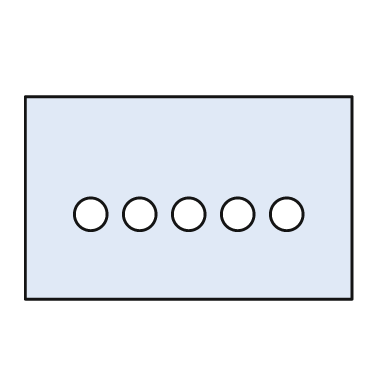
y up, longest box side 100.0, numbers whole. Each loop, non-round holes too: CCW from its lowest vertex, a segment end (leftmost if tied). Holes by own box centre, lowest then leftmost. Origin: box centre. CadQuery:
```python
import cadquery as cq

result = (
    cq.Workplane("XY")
    .moveTo(-50.0, -31.0)
    .lineTo(50.0, -31.0)
    .lineTo(50.0, 31.0)
    .lineTo(-50.0, 31.0)
    .close()
    .moveTo(-30.0, -5.0)
    .circle(5.0)
    .moveTo(-15.0, -5.0)
    .circle(5.0)
    .moveTo(0.0, -5.0)
    .circle(5.0)
    .moveTo(15.0, -5.0)
    .circle(5.0)
    .moveTo(30.0, -5.0)
    .circle(5.0)
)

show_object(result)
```